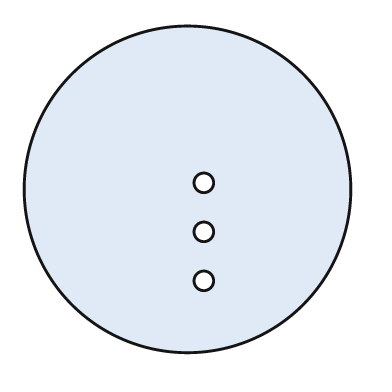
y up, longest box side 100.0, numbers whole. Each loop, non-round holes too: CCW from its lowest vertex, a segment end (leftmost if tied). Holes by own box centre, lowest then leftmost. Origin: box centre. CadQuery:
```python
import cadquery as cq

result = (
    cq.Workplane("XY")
    .moveTo(0.0, 0.0)
    .circle(50.0)
    .moveTo(5.0, -28.0)
    .circle(3.0)
    .moveTo(5.0, -13.0)
    .circle(3.0)
    .moveTo(5.0, 2.0)
    .circle(3.0)
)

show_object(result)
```